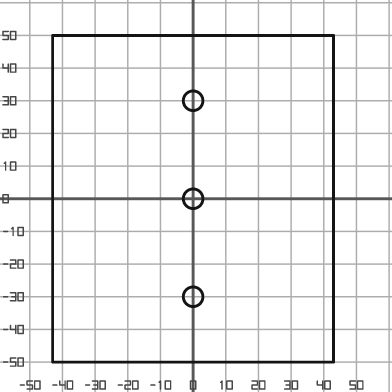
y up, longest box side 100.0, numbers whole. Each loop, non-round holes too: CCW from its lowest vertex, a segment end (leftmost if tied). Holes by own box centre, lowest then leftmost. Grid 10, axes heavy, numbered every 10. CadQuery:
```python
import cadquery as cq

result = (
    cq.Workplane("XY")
    .moveTo(-43.0, -50.0)
    .lineTo(43.0, -50.0)
    .lineTo(43.0, 50.0)
    .lineTo(-43.0, 50.0)
    .close()
    .moveTo(0.0, -30.0)
    .circle(3.0)
    .moveTo(0.0, 0.0)
    .circle(3.0)
    .moveTo(0.0, 30.0)
    .circle(3.0)
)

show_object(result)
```